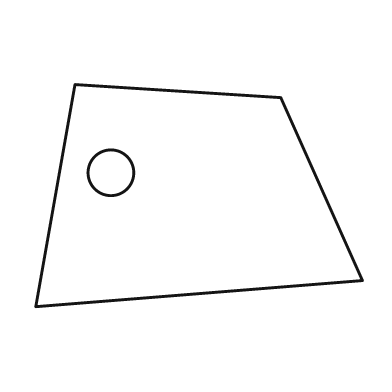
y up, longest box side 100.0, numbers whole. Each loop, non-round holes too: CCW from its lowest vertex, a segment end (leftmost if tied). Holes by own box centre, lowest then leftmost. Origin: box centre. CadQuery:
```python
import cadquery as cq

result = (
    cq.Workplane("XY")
    .moveTo(-50.0, -34.0)
    .lineTo(50.0, -26.0)
    .lineTo(25.0, 30.0)
    .lineTo(-38.0, 34.0)
    .close()
    .moveTo(-27.0, 7.0)
    .circle(7.0)
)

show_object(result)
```